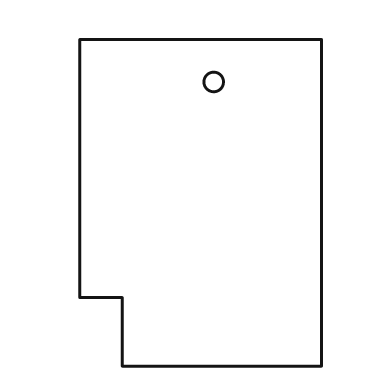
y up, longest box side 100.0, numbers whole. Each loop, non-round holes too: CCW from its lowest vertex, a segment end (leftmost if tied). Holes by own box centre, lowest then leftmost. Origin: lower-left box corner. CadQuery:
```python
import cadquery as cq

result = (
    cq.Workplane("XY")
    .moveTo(13.0, 0.0)
    .lineTo(74.0, 0.0)
    .lineTo(74.0, 100.0)
    .lineTo(0.0, 100.0)
    .lineTo(0.0, 21.0)
    .lineTo(13.0, 21.0)
    .close()
    .moveTo(41.0, 87.0)
    .circle(3.0)
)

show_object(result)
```